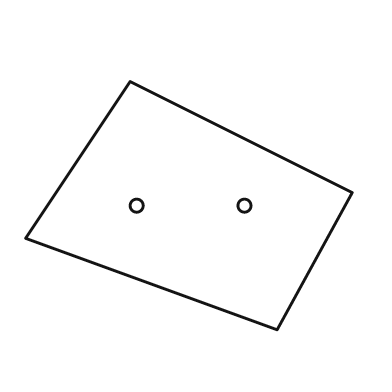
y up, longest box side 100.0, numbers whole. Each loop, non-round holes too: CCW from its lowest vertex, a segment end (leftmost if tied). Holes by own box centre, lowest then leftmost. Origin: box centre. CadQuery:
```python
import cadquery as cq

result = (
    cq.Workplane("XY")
    .moveTo(27.0, -38.0)
    .lineTo(50.0, 4.0)
    .lineTo(-18.0, 38.0)
    .lineTo(-50.0, -10.0)
    .close()
    .moveTo(-16.0, 0.0)
    .circle(2.0)
    .moveTo(17.0, 0.0)
    .circle(2.0)
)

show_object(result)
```